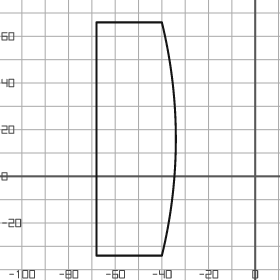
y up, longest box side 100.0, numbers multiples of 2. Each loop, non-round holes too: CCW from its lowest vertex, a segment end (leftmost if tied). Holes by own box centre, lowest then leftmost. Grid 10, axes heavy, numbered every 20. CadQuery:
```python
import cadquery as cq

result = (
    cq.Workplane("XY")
    .moveTo(-68.0, -34.0)
    .lineTo(-40.0, -34.0)
    .threePointArc((-34.0, 16.0), (-40.0, 66.0))
    .lineTo(-68.0, 66.0)
    .close()
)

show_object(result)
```